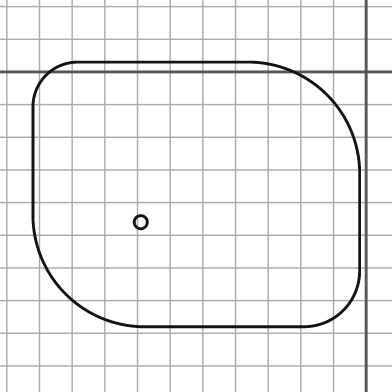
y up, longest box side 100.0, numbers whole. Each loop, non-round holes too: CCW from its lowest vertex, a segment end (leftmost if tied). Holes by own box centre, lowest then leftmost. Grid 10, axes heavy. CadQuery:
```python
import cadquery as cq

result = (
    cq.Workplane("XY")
    .moveTo(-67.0, -78.0)
    .lineTo(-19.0, -78.0)
    .threePointArc((-7.0, -73.0), (-2.0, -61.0))
    .lineTo(-2.0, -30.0)
    .threePointArc((-12.0, -7.0), (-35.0, 3.0))
    .lineTo(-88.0, 3.0)
    .threePointArc((-98.0, -1.0), (-102.0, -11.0))
    .lineTo(-102.0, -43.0)
    .threePointArc((-92.0, -68.0), (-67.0, -78.0))
    .close()
    .moveTo(-69.0, -46.0)
    .circle(2.0)
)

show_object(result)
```